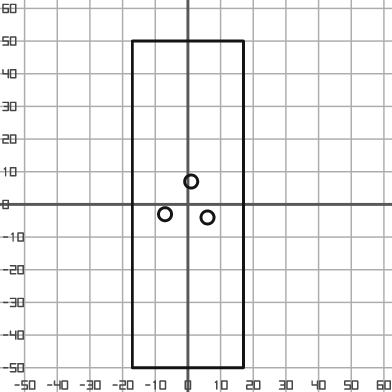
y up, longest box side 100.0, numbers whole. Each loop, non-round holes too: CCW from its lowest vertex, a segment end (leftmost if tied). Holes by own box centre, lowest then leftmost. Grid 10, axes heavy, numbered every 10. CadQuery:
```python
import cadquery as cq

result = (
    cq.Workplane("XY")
    .moveTo(-17.0, -50.0)
    .lineTo(17.0, -50.0)
    .lineTo(17.0, 50.0)
    .lineTo(-17.0, 50.0)
    .close()
    .moveTo(6.0, -4.0)
    .circle(2.0)
    .moveTo(-7.0, -3.0)
    .circle(2.0)
    .moveTo(1.0, 7.0)
    .circle(2.0)
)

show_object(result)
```